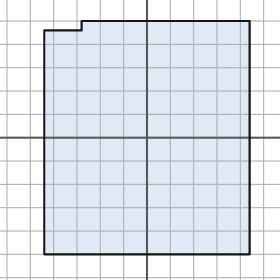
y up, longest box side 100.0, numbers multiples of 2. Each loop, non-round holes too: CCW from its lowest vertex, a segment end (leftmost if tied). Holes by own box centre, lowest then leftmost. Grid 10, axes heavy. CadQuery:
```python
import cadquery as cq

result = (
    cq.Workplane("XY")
    .moveTo(-44.0, -50.0)
    .lineTo(44.0, -50.0)
    .lineTo(44.0, 50.0)
    .lineTo(-28.0, 50.0)
    .lineTo(-28.0, 46.0)
    .lineTo(-44.0, 46.0)
    .close()
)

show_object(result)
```